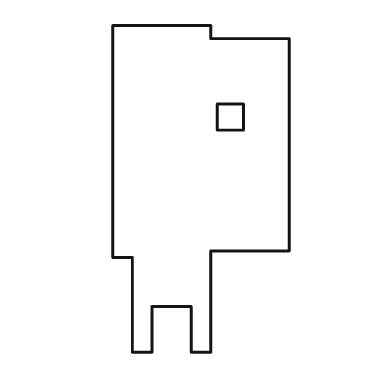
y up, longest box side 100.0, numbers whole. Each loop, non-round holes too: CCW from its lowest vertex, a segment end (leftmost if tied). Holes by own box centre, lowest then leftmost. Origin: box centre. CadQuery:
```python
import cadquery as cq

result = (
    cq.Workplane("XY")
    .moveTo(-21.0, -50.0)
    .lineTo(-15.0, -50.0)
    .lineTo(-15.0, -36.0)
    .lineTo(-3.0, -36.0)
    .lineTo(-3.0, -50.0)
    .lineTo(3.0, -50.0)
    .lineTo(3.0, -19.0)
    .lineTo(27.0, -19.0)
    .lineTo(27.0, 46.0)
    .lineTo(3.0, 46.0)
    .lineTo(3.0, 50.0)
    .lineTo(-27.0, 50.0)
    .lineTo(-27.0, -21.0)
    .lineTo(-21.0, -21.0)
    .close()
    .moveTo(5.0, 18.0)
    .lineTo(13.0, 18.0)
    .lineTo(13.0, 26.0)
    .lineTo(5.0, 26.0)
    .close()
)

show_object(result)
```